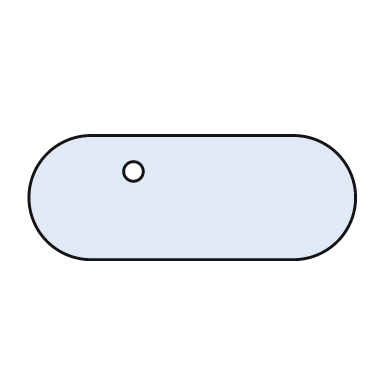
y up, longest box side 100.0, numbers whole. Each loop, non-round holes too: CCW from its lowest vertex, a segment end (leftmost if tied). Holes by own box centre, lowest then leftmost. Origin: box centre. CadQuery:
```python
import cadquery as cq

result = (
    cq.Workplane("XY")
    .moveTo(-31.0, -19.0)
    .lineTo(31.0, -19.0)
    .threePointArc((50.0, 0.0), (31.0, 19.0))
    .lineTo(-31.0, 19.0)
    .threePointArc((-50.0, 0.0), (-31.0, -19.0))
    .close()
    .moveTo(-18.0, 8.0)
    .circle(3.0)
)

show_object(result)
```